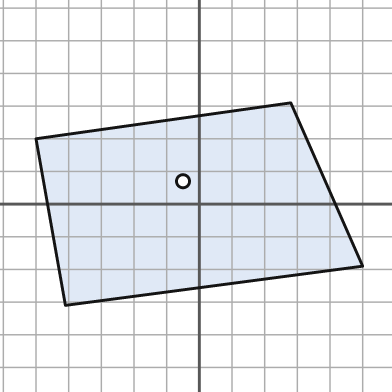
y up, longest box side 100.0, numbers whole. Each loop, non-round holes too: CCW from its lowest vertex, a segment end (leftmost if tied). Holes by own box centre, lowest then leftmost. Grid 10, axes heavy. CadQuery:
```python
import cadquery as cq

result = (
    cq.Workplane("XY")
    .moveTo(-41.0, -31.0)
    .lineTo(50.0, -19.0)
    .lineTo(28.0, 31.0)
    .lineTo(-50.0, 20.0)
    .close()
    .moveTo(-5.0, 7.0)
    .circle(2.0)
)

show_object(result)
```